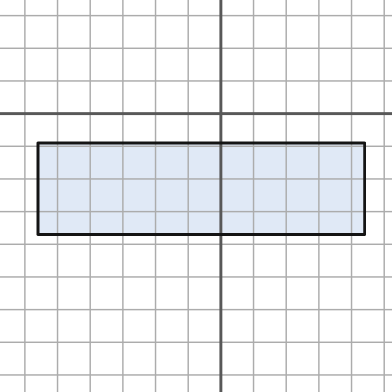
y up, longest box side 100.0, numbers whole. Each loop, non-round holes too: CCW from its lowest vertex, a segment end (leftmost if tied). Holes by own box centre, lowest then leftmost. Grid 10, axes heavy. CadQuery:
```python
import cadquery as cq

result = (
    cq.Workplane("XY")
    .moveTo(-56.0, -37.0)
    .lineTo(44.0, -37.0)
    .lineTo(44.0, -9.0)
    .lineTo(-56.0, -9.0)
    .close()
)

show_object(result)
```